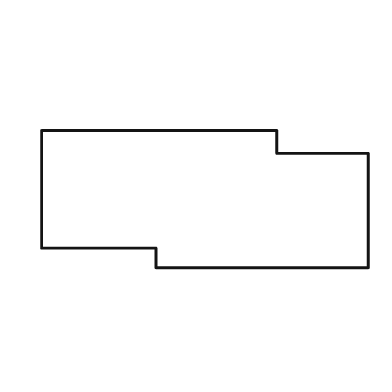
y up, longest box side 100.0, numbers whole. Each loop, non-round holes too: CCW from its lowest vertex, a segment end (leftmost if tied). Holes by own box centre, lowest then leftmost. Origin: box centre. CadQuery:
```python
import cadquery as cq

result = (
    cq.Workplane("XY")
    .moveTo(-15.0, -21.0)
    .lineTo(50.0, -21.0)
    .lineTo(50.0, 14.0)
    .lineTo(22.0, 14.0)
    .lineTo(22.0, 21.0)
    .lineTo(-50.0, 21.0)
    .lineTo(-50.0, -15.0)
    .lineTo(-15.0, -15.0)
    .close()
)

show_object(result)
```